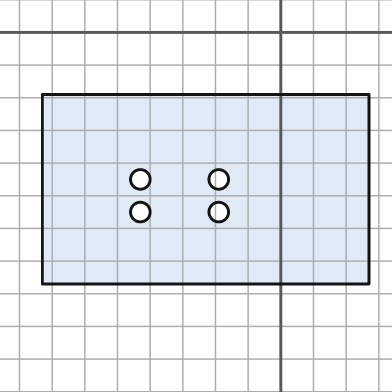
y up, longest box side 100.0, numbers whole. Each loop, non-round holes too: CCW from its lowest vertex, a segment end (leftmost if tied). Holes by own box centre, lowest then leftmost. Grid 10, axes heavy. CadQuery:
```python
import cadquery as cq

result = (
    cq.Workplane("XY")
    .moveTo(-73.0, -77.0)
    .lineTo(27.0, -77.0)
    .lineTo(27.0, -19.0)
    .lineTo(-73.0, -19.0)
    .close()
    .moveTo(-43.0, -55.0)
    .circle(3.0)
    .moveTo(-19.0, -55.0)
    .circle(3.0)
    .moveTo(-43.0, -45.0)
    .circle(3.0)
    .moveTo(-19.0, -45.0)
    .circle(3.0)
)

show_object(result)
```